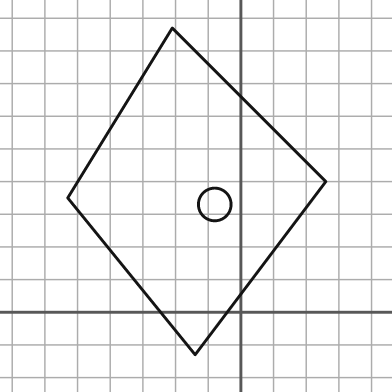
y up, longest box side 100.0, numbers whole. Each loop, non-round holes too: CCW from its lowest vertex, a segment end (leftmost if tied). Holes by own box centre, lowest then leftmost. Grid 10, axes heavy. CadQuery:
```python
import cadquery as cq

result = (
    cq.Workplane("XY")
    .moveTo(-14.0, -13.0)
    .lineTo(26.0, 40.0)
    .lineTo(-21.0, 87.0)
    .lineTo(-53.0, 35.0)
    .close()
    .moveTo(-8.0, 33.0)
    .circle(5.0)
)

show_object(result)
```